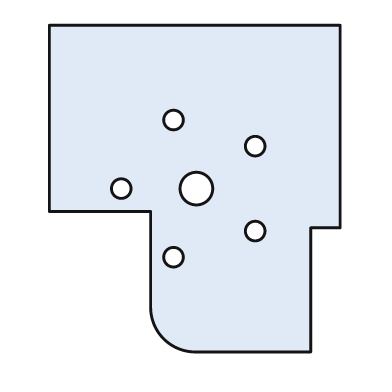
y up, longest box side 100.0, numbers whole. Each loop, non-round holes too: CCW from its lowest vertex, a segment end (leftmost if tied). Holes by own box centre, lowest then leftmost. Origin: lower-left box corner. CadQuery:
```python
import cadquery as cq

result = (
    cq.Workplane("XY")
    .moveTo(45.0, 0.0)
    .lineTo(80.0, 0.0)
    .lineTo(80.0, 38.0)
    .lineTo(89.0, 38.0)
    .lineTo(89.0, 100.0)
    .lineTo(0.0, 100.0)
    .lineTo(0.0, 43.0)
    .lineTo(31.0, 43.0)
    .lineTo(31.0, 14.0)
    .threePointArc((35.0, 4.0), (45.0, 0.0))
    .close()
    .moveTo(38.0, 29.0)
    .circle(3.0)
    .moveTo(63.0, 37.0)
    .circle(3.0)
    .moveTo(22.0, 50.0)
    .circle(3.0)
    .moveTo(45.0, 50.0)
    .circle(5.0)
    .moveTo(63.0, 63.0)
    .circle(3.0)
    .moveTo(38.0, 71.0)
    .circle(3.0)
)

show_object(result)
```